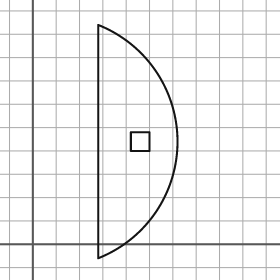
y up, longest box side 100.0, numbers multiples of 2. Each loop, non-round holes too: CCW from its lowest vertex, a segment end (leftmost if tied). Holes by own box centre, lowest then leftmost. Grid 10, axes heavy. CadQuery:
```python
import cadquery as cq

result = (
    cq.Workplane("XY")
    .moveTo(28.0, -6.0)
    .threePointArc((62.0, 44.0), (28.0, 94.0))
    .close()
    .moveTo(42.0, 40.0)
    .lineTo(50.0, 40.0)
    .lineTo(50.0, 48.0)
    .lineTo(42.0, 48.0)
    .close()
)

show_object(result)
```